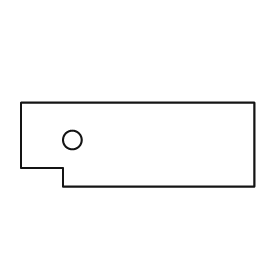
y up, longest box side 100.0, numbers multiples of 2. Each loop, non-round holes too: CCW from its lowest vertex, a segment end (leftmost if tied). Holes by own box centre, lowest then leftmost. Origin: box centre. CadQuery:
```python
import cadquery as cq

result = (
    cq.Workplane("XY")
    .moveTo(-32.0, -18.0)
    .lineTo(50.0, -18.0)
    .lineTo(50.0, 18.0)
    .lineTo(-50.0, 18.0)
    .lineTo(-50.0, -10.0)
    .lineTo(-32.0, -10.0)
    .close()
    .moveTo(-28.0, 2.0)
    .circle(4.0)
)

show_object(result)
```